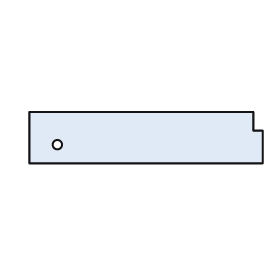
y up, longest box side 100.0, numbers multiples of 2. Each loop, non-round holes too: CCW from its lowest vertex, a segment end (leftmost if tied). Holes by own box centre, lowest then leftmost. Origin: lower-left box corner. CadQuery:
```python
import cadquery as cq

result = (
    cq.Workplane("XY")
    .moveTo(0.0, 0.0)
    .lineTo(100.0, 0.0)
    .lineTo(100.0, 14.0)
    .lineTo(96.0, 14.0)
    .lineTo(96.0, 22.0)
    .lineTo(0.0, 22.0)
    .close()
    .moveTo(12.0, 8.0)
    .circle(2.0)
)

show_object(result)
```